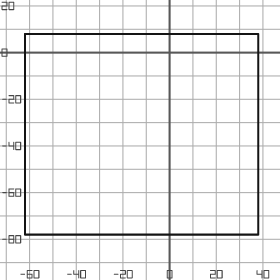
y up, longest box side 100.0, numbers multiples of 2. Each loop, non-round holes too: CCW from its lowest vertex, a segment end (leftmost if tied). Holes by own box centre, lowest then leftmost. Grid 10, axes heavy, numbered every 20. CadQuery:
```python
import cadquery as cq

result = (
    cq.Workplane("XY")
    .moveTo(-62.0, -78.0)
    .lineTo(38.0, -78.0)
    .lineTo(38.0, 8.0)
    .lineTo(-62.0, 8.0)
    .close()
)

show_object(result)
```